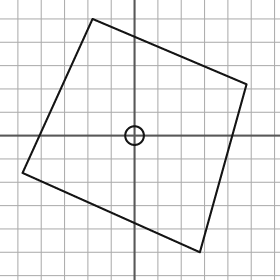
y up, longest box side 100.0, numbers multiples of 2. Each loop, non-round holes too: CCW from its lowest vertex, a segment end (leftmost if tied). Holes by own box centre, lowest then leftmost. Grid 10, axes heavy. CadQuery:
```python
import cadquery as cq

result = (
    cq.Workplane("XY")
    .moveTo(28.0, -50.0)
    .lineTo(48.0, 22.0)
    .lineTo(-18.0, 50.0)
    .lineTo(-48.0, -16.0)
    .close()
    .moveTo(0.0, 0.0)
    .circle(4.0)
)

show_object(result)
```